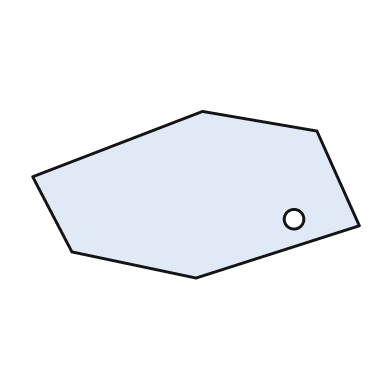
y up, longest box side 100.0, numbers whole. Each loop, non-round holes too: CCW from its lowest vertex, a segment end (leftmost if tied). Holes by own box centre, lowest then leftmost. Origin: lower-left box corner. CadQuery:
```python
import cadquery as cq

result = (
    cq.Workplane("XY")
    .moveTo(50.0, 0.0)
    .lineTo(100.0, 16.0)
    .lineTo(87.0, 45.0)
    .lineTo(52.0, 51.0)
    .lineTo(0.0, 31.0)
    .lineTo(12.0, 8.0)
    .close()
    .moveTo(80.0, 18.0)
    .circle(3.0)
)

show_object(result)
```